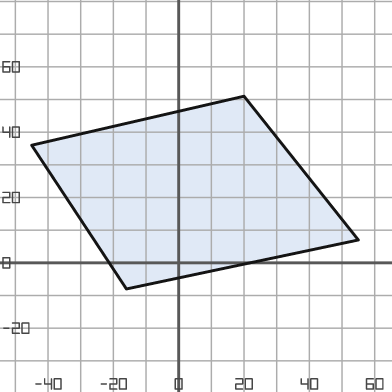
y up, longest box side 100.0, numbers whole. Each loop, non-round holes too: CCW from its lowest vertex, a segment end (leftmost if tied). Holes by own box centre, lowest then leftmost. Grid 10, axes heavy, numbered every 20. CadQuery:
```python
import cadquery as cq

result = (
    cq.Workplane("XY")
    .moveTo(-16.0, -8.0)
    .lineTo(55.0, 7.0)
    .lineTo(20.0, 51.0)
    .lineTo(-45.0, 36.0)
    .close()
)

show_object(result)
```